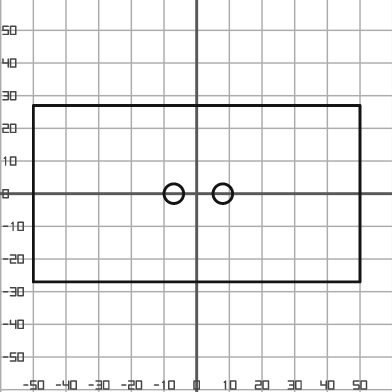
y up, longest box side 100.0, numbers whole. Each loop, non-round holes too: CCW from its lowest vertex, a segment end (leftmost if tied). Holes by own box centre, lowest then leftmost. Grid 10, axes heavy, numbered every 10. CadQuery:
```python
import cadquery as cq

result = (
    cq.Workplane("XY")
    .moveTo(-50.0, -27.0)
    .lineTo(50.0, -27.0)
    .lineTo(50.0, 27.0)
    .lineTo(-50.0, 27.0)
    .close()
    .moveTo(-7.0, 0.0)
    .circle(3.0)
    .moveTo(8.0, 0.0)
    .circle(3.0)
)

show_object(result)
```